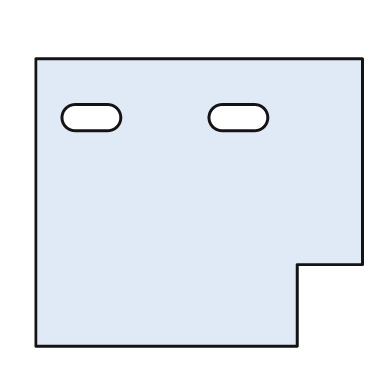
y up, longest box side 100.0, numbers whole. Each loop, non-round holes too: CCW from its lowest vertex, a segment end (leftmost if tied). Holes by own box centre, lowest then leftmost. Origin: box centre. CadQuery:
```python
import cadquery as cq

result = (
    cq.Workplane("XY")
    .moveTo(-50.0, -44.0)
    .lineTo(30.0, -44.0)
    .lineTo(30.0, -19.0)
    .lineTo(50.0, -19.0)
    .lineTo(50.0, 44.0)
    .lineTo(-50.0, 44.0)
    .close()
    .moveTo(-38.0, 22.0)
    .lineTo(-28.0, 22.0)
    .threePointArc((-24.0, 26.0), (-28.0, 30.0))
    .lineTo(-38.0, 30.0)
    .threePointArc((-42.0, 26.0), (-38.0, 22.0))
    .close()
    .moveTo(7.0, 22.0)
    .lineTo(17.0, 22.0)
    .threePointArc((21.0, 26.0), (17.0, 30.0))
    .lineTo(7.0, 30.0)
    .threePointArc((3.0, 26.0), (7.0, 22.0))
    .close()
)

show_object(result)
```